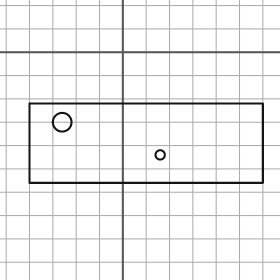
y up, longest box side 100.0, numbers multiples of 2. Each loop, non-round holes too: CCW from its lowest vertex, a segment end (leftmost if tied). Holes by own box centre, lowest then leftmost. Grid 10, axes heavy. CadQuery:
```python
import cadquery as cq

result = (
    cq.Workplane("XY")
    .moveTo(-40.0, -56.0)
    .lineTo(60.0, -56.0)
    .lineTo(60.0, -22.0)
    .lineTo(-40.0, -22.0)
    .close()
    .moveTo(16.0, -44.0)
    .circle(2.0)
    .moveTo(-26.0, -30.0)
    .circle(4.0)
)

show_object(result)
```